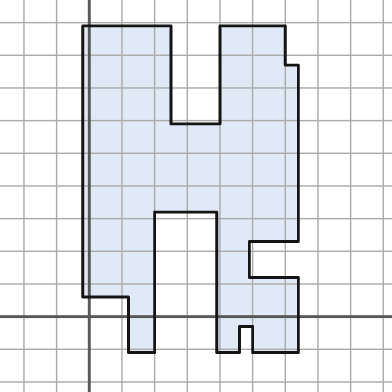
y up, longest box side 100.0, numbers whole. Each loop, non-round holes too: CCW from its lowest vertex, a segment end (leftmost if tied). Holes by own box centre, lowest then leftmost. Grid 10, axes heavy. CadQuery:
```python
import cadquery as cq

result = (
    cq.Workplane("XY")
    .moveTo(12.0, -11.0)
    .lineTo(20.0, -11.0)
    .lineTo(20.0, 32.0)
    .lineTo(39.0, 32.0)
    .lineTo(39.0, -11.0)
    .lineTo(46.0, -11.0)
    .lineTo(46.0, -3.0)
    .lineTo(50.0, -3.0)
    .lineTo(50.0, -11.0)
    .lineTo(64.0, -11.0)
    .lineTo(64.0, 12.0)
    .lineTo(49.0, 12.0)
    .lineTo(49.0, 23.0)
    .lineTo(64.0, 23.0)
    .lineTo(64.0, 77.0)
    .lineTo(60.0, 77.0)
    .lineTo(60.0, 89.0)
    .lineTo(40.0, 89.0)
    .lineTo(40.0, 59.0)
    .lineTo(25.0, 59.0)
    .lineTo(25.0, 89.0)
    .lineTo(-2.0, 89.0)
    .lineTo(-2.0, 6.0)
    .lineTo(12.0, 6.0)
    .close()
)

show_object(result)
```